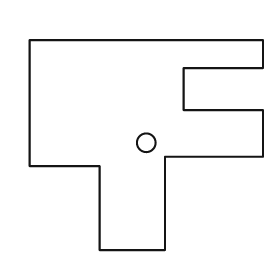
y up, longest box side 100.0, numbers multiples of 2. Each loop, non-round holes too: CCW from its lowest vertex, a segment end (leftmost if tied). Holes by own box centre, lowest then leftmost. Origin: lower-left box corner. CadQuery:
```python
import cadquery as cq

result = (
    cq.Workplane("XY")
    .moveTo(30.0, 0.0)
    .lineTo(58.0, 0.0)
    .lineTo(58.0, 40.0)
    .lineTo(100.0, 40.0)
    .lineTo(100.0, 60.0)
    .lineTo(66.0, 60.0)
    .lineTo(66.0, 78.0)
    .lineTo(100.0, 78.0)
    .lineTo(100.0, 90.0)
    .lineTo(0.0, 90.0)
    .lineTo(0.0, 36.0)
    .lineTo(30.0, 36.0)
    .close()
    .moveTo(50.0, 46.0)
    .circle(4.0)
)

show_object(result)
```